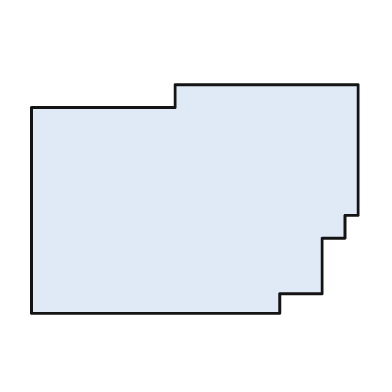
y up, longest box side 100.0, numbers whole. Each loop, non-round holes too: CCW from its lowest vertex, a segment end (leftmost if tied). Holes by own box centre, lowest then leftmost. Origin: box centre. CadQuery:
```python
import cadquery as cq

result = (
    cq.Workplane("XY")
    .moveTo(-50.0, -35.0)
    .lineTo(26.0, -35.0)
    .lineTo(26.0, -29.0)
    .lineTo(39.0, -29.0)
    .lineTo(39.0, -12.0)
    .lineTo(46.0, -12.0)
    .lineTo(46.0, -5.0)
    .lineTo(50.0, -5.0)
    .lineTo(50.0, 35.0)
    .lineTo(-6.0, 35.0)
    .lineTo(-6.0, 28.0)
    .lineTo(-50.0, 28.0)
    .close()
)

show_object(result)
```